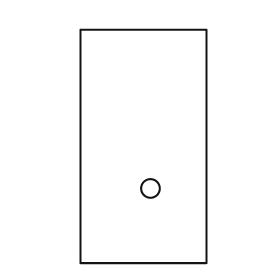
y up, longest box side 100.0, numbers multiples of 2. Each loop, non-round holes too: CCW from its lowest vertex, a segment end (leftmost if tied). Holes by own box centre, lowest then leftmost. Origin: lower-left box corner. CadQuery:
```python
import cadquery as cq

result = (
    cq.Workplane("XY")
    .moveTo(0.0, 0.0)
    .lineTo(54.0, 0.0)
    .lineTo(54.0, 100.0)
    .lineTo(0.0, 100.0)
    .close()
    .moveTo(30.0, 32.0)
    .circle(4.0)
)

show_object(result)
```